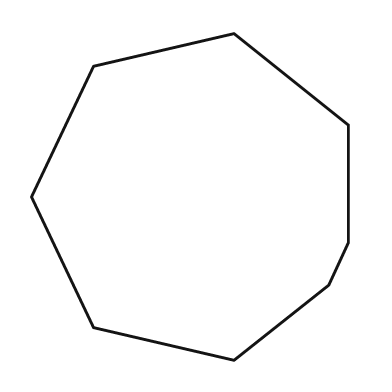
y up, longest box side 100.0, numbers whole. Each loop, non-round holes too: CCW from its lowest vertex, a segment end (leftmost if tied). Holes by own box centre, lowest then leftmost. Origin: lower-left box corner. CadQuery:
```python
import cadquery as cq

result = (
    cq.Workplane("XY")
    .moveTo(62.0, 0.0)
    .lineTo(91.0, 23.0)
    .lineTo(97.0, 36.0)
    .lineTo(97.0, 72.0)
    .lineTo(62.0, 100.0)
    .lineTo(19.0, 90.0)
    .lineTo(0.0, 50.0)
    .lineTo(19.0, 10.0)
    .close()
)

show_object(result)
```